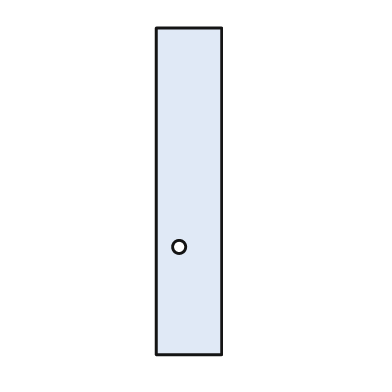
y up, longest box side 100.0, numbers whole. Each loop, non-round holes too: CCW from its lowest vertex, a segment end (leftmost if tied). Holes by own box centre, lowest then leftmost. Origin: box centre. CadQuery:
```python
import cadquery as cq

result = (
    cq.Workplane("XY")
    .moveTo(-10.0, -50.0)
    .lineTo(10.0, -50.0)
    .lineTo(10.0, 50.0)
    .lineTo(-10.0, 50.0)
    .close()
    .moveTo(-3.0, -17.0)
    .circle(2.0)
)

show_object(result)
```